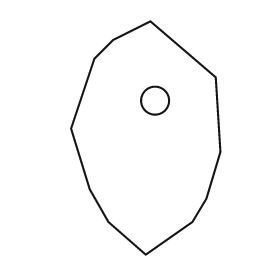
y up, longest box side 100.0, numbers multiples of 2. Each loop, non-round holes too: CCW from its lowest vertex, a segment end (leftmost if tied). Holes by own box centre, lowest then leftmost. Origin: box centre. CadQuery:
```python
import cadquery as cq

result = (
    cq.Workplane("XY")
    .moveTo(0.0, -50.0)
    .lineTo(20.0, -36.0)
    .lineTo(26.0, -26.0)
    .lineTo(32.0, -6.0)
    .lineTo(30.0, 26.0)
    .lineTo(2.0, 50.0)
    .lineTo(-14.0, 42.0)
    .lineTo(-22.0, 34.0)
    .lineTo(-32.0, 4.0)
    .lineTo(-24.0, -22.0)
    .lineTo(-16.0, -36.0)
    .close()
    .moveTo(4.0, 16.0)
    .circle(6.0)
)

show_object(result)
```